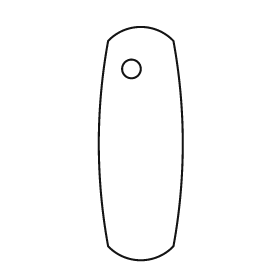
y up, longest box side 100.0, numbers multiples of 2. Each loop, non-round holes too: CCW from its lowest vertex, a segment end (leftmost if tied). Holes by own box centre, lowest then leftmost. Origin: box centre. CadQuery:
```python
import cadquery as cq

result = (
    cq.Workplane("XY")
    .moveTo(-14.0, -44.0)
    .threePointArc((0.0, -50.0), (14.0, -44.0))
    .threePointArc((18.0, 0.0), (14.0, 44.0))
    .threePointArc((0.0, 50.0), (-14.0, 44.0))
    .threePointArc((-18.0, 0.0), (-14.0, -44.0))
    .close()
    .moveTo(-4.0, 32.0)
    .circle(4.0)
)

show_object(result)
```